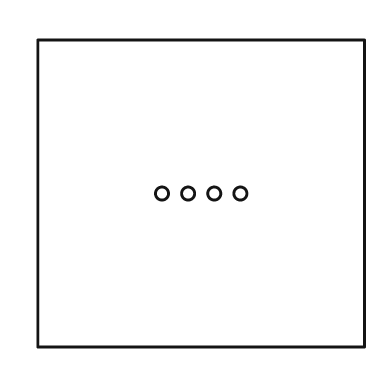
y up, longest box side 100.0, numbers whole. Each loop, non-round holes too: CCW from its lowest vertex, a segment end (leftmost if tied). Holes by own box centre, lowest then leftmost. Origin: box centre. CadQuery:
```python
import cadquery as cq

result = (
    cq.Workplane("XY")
    .moveTo(-50.0, -47.0)
    .lineTo(50.0, -47.0)
    .lineTo(50.0, 47.0)
    .lineTo(-50.0, 47.0)
    .close()
    .moveTo(-12.0, 0.0)
    .circle(2.0)
    .moveTo(-4.0, 0.0)
    .circle(2.0)
    .moveTo(4.0, 0.0)
    .circle(2.0)
    .moveTo(12.0, 0.0)
    .circle(2.0)
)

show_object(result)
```